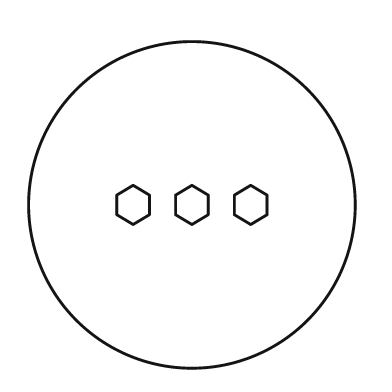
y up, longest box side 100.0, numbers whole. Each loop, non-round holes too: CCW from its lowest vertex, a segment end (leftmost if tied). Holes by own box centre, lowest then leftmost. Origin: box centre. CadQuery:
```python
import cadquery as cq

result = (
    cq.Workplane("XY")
    .moveTo(0.0, 0.0)
    .circle(50.0)
    .moveTo(-18.0, -6.0)
    .lineTo(-13.0, -3.0)
    .lineTo(-13.0, 3.0)
    .lineTo(-18.0, 6.0)
    .lineTo(-23.0, 3.0)
    .lineTo(-23.0, -3.0)
    .close()
    .moveTo(0.0, -6.0)
    .lineTo(5.0, -3.0)
    .lineTo(5.0, 3.0)
    .lineTo(0.0, 6.0)
    .lineTo(-5.0, 3.0)
    .lineTo(-5.0, -3.0)
    .close()
    .moveTo(18.0, -6.0)
    .lineTo(23.0, -3.0)
    .lineTo(23.0, 3.0)
    .lineTo(18.0, 6.0)
    .lineTo(13.0, 3.0)
    .lineTo(13.0, -3.0)
    .close()
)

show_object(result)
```